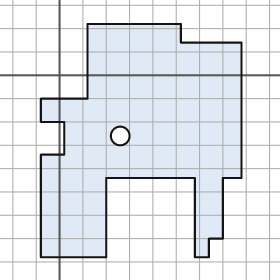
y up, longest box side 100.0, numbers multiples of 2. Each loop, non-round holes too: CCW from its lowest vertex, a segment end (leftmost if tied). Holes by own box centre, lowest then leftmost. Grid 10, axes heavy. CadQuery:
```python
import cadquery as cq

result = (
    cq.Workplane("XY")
    .moveTo(-8.0, -78.0)
    .lineTo(20.0, -78.0)
    .lineTo(20.0, -44.0)
    .lineTo(58.0, -44.0)
    .lineTo(58.0, -78.0)
    .lineTo(64.0, -78.0)
    .lineTo(64.0, -70.0)
    .lineTo(70.0, -70.0)
    .lineTo(70.0, -44.0)
    .lineTo(78.0, -44.0)
    .lineTo(78.0, 14.0)
    .lineTo(52.0, 14.0)
    .lineTo(52.0, 22.0)
    .lineTo(12.0, 22.0)
    .lineTo(12.0, -10.0)
    .lineTo(-8.0, -10.0)
    .lineTo(-8.0, -20.0)
    .lineTo(2.0, -20.0)
    .lineTo(2.0, -34.0)
    .lineTo(-8.0, -34.0)
    .close()
    .moveTo(26.0, -26.0)
    .circle(4.0)
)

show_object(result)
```